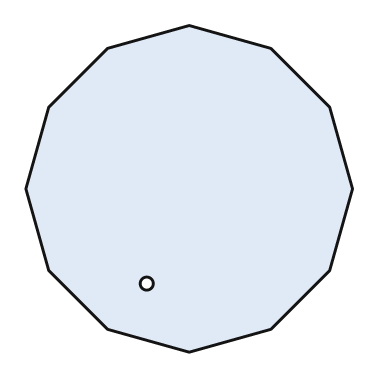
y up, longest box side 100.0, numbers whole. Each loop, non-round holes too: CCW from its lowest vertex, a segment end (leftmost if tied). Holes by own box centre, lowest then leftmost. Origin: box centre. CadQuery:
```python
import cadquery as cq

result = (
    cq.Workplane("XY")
    .moveTo(0.0, -50.0)
    .lineTo(25.0, -43.0)
    .lineTo(43.0, -25.0)
    .lineTo(50.0, 0.0)
    .lineTo(43.0, 25.0)
    .lineTo(25.0, 43.0)
    .lineTo(0.0, 50.0)
    .lineTo(-25.0, 43.0)
    .lineTo(-43.0, 25.0)
    .lineTo(-50.0, 0.0)
    .lineTo(-43.0, -25.0)
    .lineTo(-25.0, -43.0)
    .close()
    .moveTo(-13.0, -29.0)
    .circle(2.0)
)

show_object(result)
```